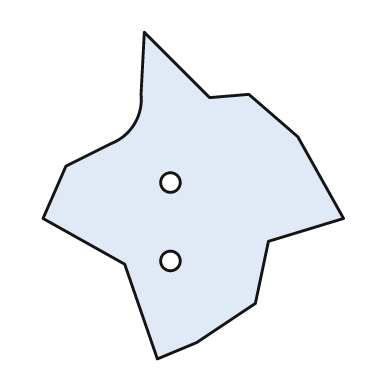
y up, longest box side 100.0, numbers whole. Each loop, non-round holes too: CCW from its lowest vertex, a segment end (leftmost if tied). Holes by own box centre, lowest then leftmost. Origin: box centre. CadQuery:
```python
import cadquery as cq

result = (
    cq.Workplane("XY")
    .moveTo(-11.0, -50.0)
    .lineTo(1.0, -45.0)
    .lineTo(19.0, -33.0)
    .lineTo(23.0, -14.0)
    .lineTo(46.0, -7.0)
    .lineTo(32.0, 18.0)
    .lineTo(17.0, 31.0)
    .lineTo(5.0, 30.0)
    .lineTo(-15.0, 50.0)
    .lineTo(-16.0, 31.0)
    .threePointArc((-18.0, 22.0), (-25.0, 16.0))
    .lineTo(-39.0, 9.0)
    .lineTo(-46.0, -7.0)
    .lineTo(-21.0, -21.0)
    .close()
    .moveTo(-7.0, -20.0)
    .circle(3.0)
    .moveTo(-7.0, 4.0)
    .circle(3.0)
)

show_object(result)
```